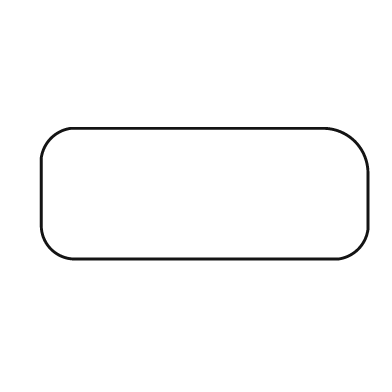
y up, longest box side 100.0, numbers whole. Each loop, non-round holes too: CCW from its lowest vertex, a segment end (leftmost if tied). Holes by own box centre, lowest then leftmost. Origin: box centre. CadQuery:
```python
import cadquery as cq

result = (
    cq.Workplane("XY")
    .moveTo(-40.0, -20.0)
    .lineTo(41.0, -20.0)
    .threePointArc((47.0, -17.0), (50.0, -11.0))
    .lineTo(50.0, 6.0)
    .threePointArc((46.0, 16.0), (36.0, 20.0))
    .lineTo(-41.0, 20.0)
    .threePointArc((-47.0, 17.0), (-50.0, 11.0))
    .lineTo(-50.0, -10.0)
    .threePointArc((-47.0, -17.0), (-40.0, -20.0))
    .close()
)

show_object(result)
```